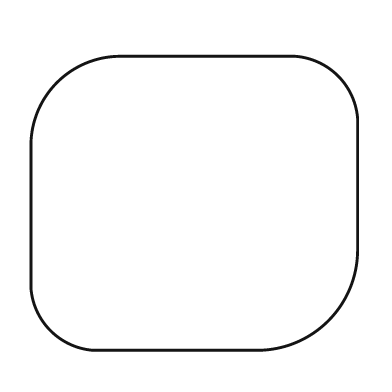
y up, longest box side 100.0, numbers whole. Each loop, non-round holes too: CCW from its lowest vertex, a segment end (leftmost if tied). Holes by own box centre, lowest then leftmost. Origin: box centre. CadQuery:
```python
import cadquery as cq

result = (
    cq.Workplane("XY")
    .moveTo(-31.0, -45.0)
    .lineTo(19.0, -45.0)
    .threePointArc((41.0, -36.0), (50.0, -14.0))
    .lineTo(50.0, 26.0)
    .threePointArc((44.0, 39.0), (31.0, 45.0))
    .lineTo(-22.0, 45.0)
    .threePointArc((-42.0, 37.0), (-50.0, 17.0))
    .lineTo(-50.0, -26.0)
    .threePointArc((-44.0, -39.0), (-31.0, -45.0))
    .close()
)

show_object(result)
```